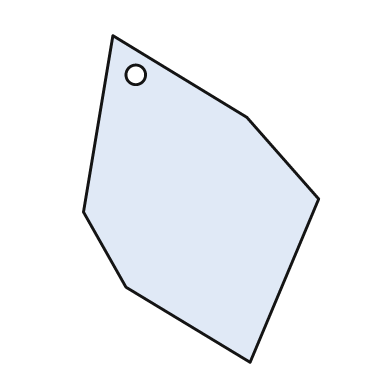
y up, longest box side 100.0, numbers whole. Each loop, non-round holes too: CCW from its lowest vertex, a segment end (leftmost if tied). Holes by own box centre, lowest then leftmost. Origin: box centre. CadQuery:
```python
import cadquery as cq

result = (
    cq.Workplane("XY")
    .moveTo(15.0, -50.0)
    .lineTo(36.0, 0.0)
    .lineTo(14.0, 25.0)
    .lineTo(-27.0, 50.0)
    .lineTo(-36.0, -4.0)
    .lineTo(-23.0, -27.0)
    .close()
    .moveTo(-20.0, 38.0)
    .circle(3.0)
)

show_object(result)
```